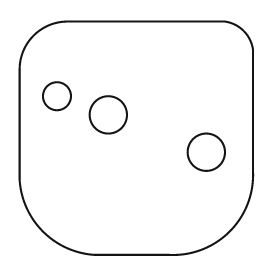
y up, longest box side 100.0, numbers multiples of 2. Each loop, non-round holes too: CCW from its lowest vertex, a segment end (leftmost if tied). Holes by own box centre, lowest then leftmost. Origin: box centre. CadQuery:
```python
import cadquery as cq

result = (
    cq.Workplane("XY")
    .moveTo(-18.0, -50.0)
    .lineTo(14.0, -50.0)
    .threePointArc((40.0, -40.0), (50.0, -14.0))
    .lineTo(50.0, 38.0)
    .threePointArc((46.0, 46.0), (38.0, 50.0))
    .lineTo(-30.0, 50.0)
    .threePointArc((-44.0, 44.0), (-50.0, 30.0))
    .lineTo(-50.0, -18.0)
    .threePointArc((-40.0, -40.0), (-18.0, -50.0))
    .close()
    .moveTo(30.0, -6.0)
    .circle(8.0)
    .moveTo(-12.0, 10.0)
    .circle(8.0)
    .moveTo(-34.0, 18.0)
    .circle(6.0)
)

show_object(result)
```